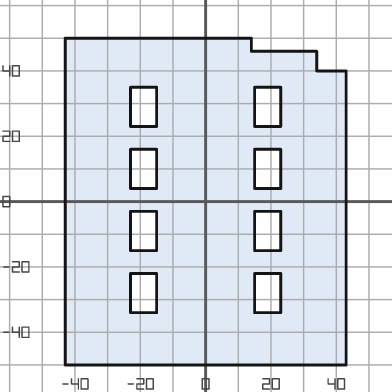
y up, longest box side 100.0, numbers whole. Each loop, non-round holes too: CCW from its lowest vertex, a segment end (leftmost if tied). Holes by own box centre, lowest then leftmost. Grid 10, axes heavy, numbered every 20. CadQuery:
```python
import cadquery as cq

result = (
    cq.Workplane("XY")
    .moveTo(-43.0, -50.0)
    .lineTo(43.0, -50.0)
    .lineTo(43.0, 40.0)
    .lineTo(34.0, 40.0)
    .lineTo(34.0, 46.0)
    .lineTo(14.0, 46.0)
    .lineTo(14.0, 50.0)
    .lineTo(-43.0, 50.0)
    .close()
    .moveTo(-23.0, -34.0)
    .lineTo(-15.0, -34.0)
    .lineTo(-15.0, -22.0)
    .lineTo(-23.0, -22.0)
    .close()
    .moveTo(15.0, -34.0)
    .lineTo(23.0, -34.0)
    .lineTo(23.0, -22.0)
    .lineTo(15.0, -22.0)
    .close()
    .moveTo(-23.0, -15.0)
    .lineTo(-15.0, -15.0)
    .lineTo(-15.0, -3.0)
    .lineTo(-23.0, -3.0)
    .close()
    .moveTo(15.0, -15.0)
    .lineTo(23.0, -15.0)
    .lineTo(23.0, -3.0)
    .lineTo(15.0, -3.0)
    .close()
    .moveTo(-23.0, 4.0)
    .lineTo(-15.0, 4.0)
    .lineTo(-15.0, 16.0)
    .lineTo(-23.0, 16.0)
    .close()
    .moveTo(15.0, 4.0)
    .lineTo(23.0, 4.0)
    .lineTo(23.0, 16.0)
    .lineTo(15.0, 16.0)
    .close()
    .moveTo(-23.0, 23.0)
    .lineTo(-15.0, 23.0)
    .lineTo(-15.0, 35.0)
    .lineTo(-23.0, 35.0)
    .close()
    .moveTo(15.0, 23.0)
    .lineTo(23.0, 23.0)
    .lineTo(23.0, 35.0)
    .lineTo(15.0, 35.0)
    .close()
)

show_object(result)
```